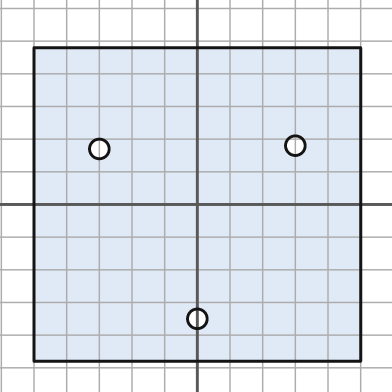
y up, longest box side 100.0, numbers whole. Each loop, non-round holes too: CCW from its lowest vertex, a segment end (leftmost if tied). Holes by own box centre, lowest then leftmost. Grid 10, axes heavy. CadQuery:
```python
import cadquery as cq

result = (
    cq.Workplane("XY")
    .moveTo(-50.0, -48.0)
    .lineTo(50.0, -48.0)
    .lineTo(50.0, 48.0)
    .lineTo(-50.0, 48.0)
    .close()
    .moveTo(0.0, -35.0)
    .circle(3.0)
    .moveTo(-30.0, 17.0)
    .circle(3.0)
    .moveTo(30.0, 18.0)
    .circle(3.0)
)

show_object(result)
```